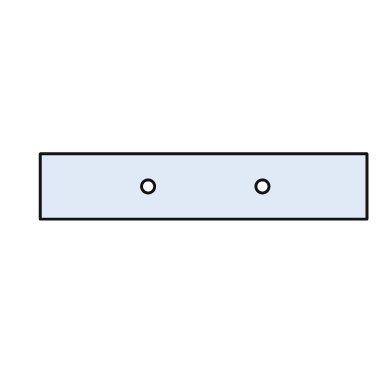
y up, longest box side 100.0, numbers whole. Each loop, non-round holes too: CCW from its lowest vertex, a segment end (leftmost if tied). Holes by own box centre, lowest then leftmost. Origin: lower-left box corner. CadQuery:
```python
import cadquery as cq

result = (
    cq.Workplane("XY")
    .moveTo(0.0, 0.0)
    .lineTo(100.0, 0.0)
    .lineTo(100.0, 20.0)
    .lineTo(0.0, 20.0)
    .close()
    .moveTo(33.0, 10.0)
    .circle(2.0)
    .moveTo(68.0, 10.0)
    .circle(2.0)
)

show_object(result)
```